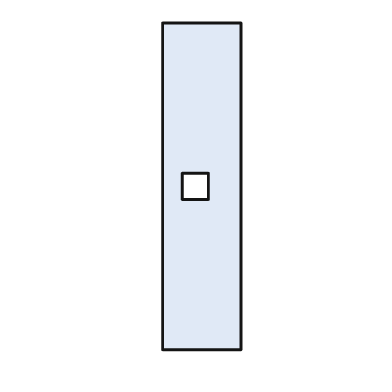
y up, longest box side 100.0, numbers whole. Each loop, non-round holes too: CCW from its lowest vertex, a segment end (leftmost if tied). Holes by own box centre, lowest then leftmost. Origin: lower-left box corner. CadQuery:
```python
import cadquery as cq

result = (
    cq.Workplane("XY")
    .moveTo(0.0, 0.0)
    .lineTo(24.0, 0.0)
    .lineTo(24.0, 100.0)
    .lineTo(0.0, 100.0)
    .close()
    .moveTo(6.0, 46.0)
    .lineTo(14.0, 46.0)
    .lineTo(14.0, 54.0)
    .lineTo(6.0, 54.0)
    .close()
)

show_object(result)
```